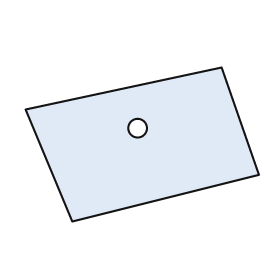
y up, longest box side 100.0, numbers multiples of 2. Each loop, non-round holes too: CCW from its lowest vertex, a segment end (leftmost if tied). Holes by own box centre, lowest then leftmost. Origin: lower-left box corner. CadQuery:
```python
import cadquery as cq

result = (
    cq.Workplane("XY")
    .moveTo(20.0, 0.0)
    .lineTo(100.0, 20.0)
    .lineTo(84.0, 66.0)
    .lineTo(0.0, 48.0)
    .close()
    .moveTo(48.0, 40.0)
    .circle(4.0)
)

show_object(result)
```